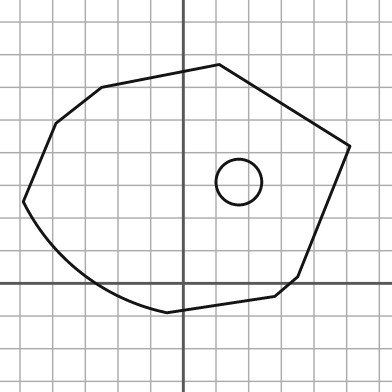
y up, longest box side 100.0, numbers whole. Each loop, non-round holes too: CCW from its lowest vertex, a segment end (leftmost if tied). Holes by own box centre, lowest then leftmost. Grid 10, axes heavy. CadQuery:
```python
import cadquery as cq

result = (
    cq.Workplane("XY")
    .moveTo(-5.0, -9.0)
    .lineTo(28.0, -4.0)
    .lineTo(35.0, 2.0)
    .lineTo(51.0, 42.0)
    .lineTo(11.0, 67.0)
    .lineTo(-25.0, 60.0)
    .lineTo(-39.0, 49.0)
    .lineTo(-49.0, 25.0)
    .threePointArc((-31.0, 3.0), (-5.0, -9.0))
    .close()
    .moveTo(17.0, 31.0)
    .circle(7.0)
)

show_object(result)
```